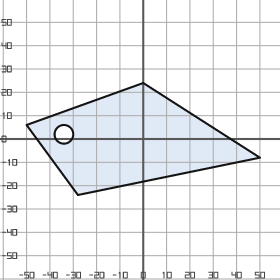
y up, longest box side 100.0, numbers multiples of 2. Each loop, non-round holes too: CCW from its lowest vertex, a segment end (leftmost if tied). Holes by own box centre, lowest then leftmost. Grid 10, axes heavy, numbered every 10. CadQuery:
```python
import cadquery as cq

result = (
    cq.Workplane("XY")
    .moveTo(-28.0, -24.0)
    .lineTo(50.0, -8.0)
    .lineTo(0.0, 24.0)
    .lineTo(-50.0, 6.0)
    .close()
    .moveTo(-34.0, 2.0)
    .circle(4.0)
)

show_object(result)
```